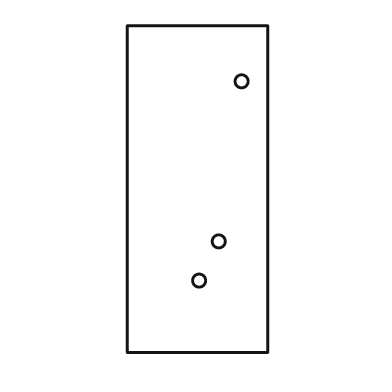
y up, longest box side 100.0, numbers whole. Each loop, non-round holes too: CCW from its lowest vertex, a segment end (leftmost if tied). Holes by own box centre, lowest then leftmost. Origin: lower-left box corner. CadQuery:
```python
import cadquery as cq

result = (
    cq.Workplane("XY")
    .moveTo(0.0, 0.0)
    .lineTo(43.0, 0.0)
    .lineTo(43.0, 100.0)
    .lineTo(0.0, 100.0)
    .close()
    .moveTo(22.0, 22.0)
    .circle(2.0)
    .moveTo(28.0, 34.0)
    .circle(2.0)
    .moveTo(35.0, 83.0)
    .circle(2.0)
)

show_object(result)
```